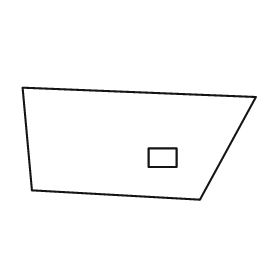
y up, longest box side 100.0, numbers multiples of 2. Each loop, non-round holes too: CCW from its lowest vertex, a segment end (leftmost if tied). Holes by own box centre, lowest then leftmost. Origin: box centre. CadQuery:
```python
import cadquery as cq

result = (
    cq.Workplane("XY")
    .moveTo(26.0, -24.0)
    .lineTo(50.0, 20.0)
    .lineTo(-50.0, 24.0)
    .lineTo(-46.0, -20.0)
    .close()
    .moveTo(4.0, -10.0)
    .lineTo(16.0, -10.0)
    .lineTo(16.0, -2.0)
    .lineTo(4.0, -2.0)
    .close()
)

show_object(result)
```